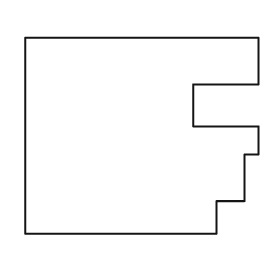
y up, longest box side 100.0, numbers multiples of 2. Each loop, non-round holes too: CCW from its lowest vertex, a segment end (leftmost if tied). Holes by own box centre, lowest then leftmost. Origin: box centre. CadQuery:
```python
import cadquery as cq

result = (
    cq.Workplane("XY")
    .moveTo(-50.0, -42.0)
    .lineTo(32.0, -42.0)
    .lineTo(32.0, -28.0)
    .lineTo(44.0, -28.0)
    .lineTo(44.0, -8.0)
    .lineTo(50.0, -8.0)
    .lineTo(50.0, 4.0)
    .lineTo(22.0, 4.0)
    .lineTo(22.0, 22.0)
    .lineTo(50.0, 22.0)
    .lineTo(50.0, 42.0)
    .lineTo(-50.0, 42.0)
    .close()
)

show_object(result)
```